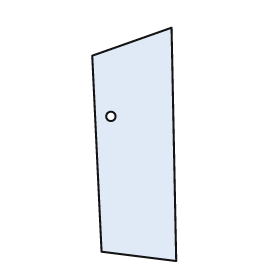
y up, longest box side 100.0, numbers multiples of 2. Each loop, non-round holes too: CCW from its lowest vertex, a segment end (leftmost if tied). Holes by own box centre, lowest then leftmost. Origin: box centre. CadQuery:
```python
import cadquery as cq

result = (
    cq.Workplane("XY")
    .moveTo(18.0, -50.0)
    .lineTo(16.0, 50.0)
    .lineTo(-18.0, 38.0)
    .lineTo(-14.0, -46.0)
    .close()
    .moveTo(-10.0, 12.0)
    .circle(2.0)
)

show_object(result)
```